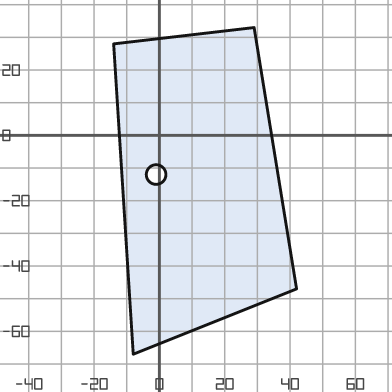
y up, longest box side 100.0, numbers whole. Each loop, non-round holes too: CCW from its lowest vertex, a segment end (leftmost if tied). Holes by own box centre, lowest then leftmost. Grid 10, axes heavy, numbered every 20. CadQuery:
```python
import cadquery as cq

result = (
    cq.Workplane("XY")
    .moveTo(-8.0, -67.0)
    .lineTo(42.0, -47.0)
    .lineTo(29.0, 33.0)
    .lineTo(-14.0, 28.0)
    .close()
    .moveTo(-1.0, -12.0)
    .circle(3.0)
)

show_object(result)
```